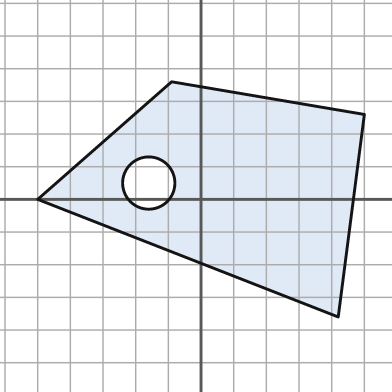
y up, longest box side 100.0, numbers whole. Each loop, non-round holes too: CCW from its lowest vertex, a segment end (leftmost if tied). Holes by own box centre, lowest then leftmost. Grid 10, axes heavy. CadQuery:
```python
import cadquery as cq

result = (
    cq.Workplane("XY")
    .moveTo(42.0, -36.0)
    .lineTo(50.0, 26.0)
    .lineTo(-9.0, 36.0)
    .lineTo(-50.0, 0.0)
    .close()
    .moveTo(-16.0, 5.0)
    .circle(8.0)
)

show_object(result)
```